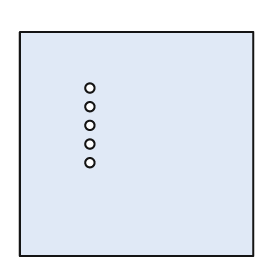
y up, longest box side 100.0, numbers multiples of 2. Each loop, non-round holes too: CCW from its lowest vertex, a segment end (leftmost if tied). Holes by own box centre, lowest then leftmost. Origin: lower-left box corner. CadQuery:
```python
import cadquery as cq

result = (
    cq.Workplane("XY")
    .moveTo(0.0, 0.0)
    .lineTo(100.0, 0.0)
    .lineTo(100.0, 96.0)
    .lineTo(0.0, 96.0)
    .close()
    .moveTo(30.0, 40.0)
    .circle(2.0)
    .moveTo(30.0, 48.0)
    .circle(2.0)
    .moveTo(30.0, 56.0)
    .circle(2.0)
    .moveTo(30.0, 64.0)
    .circle(2.0)
    .moveTo(30.0, 72.0)
    .circle(2.0)
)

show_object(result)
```